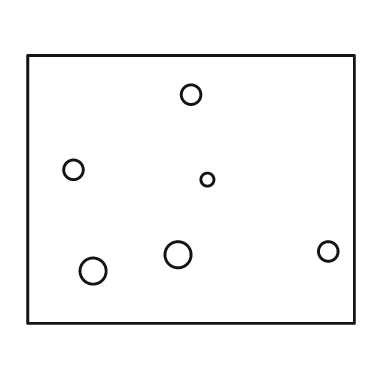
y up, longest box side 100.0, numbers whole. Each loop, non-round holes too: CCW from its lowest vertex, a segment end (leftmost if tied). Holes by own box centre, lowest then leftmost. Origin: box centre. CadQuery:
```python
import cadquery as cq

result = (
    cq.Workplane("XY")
    .moveTo(-50.0, -41.0)
    .lineTo(50.0, -41.0)
    .lineTo(50.0, 41.0)
    .lineTo(-50.0, 41.0)
    .close()
    .moveTo(-30.0, -25.0)
    .circle(4.0)
    .moveTo(-4.0, -20.0)
    .circle(4.0)
    .moveTo(42.0, -19.0)
    .circle(3.0)
    .moveTo(5.0, 3.0)
    .circle(2.0)
    .moveTo(-36.0, 6.0)
    .circle(3.0)
    .moveTo(0.0, 29.0)
    .circle(3.0)
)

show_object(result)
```